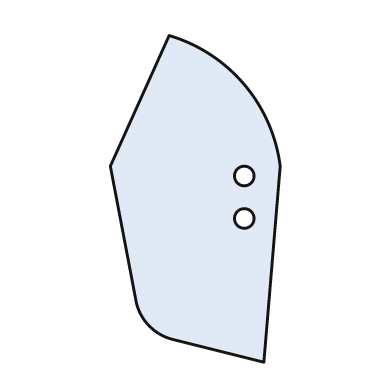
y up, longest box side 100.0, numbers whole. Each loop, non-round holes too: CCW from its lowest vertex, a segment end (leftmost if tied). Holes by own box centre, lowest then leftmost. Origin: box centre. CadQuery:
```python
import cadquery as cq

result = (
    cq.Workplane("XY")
    .moveTo(21.0, -50.0)
    .lineTo(26.0, 10.0)
    .threePointArc((15.0, 35.0), (-8.0, 50.0))
    .lineTo(-26.0, 10.0)
    .lineTo(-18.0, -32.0)
    .threePointArc((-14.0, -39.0), (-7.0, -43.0))
    .close()
    .moveTo(15.0, -6.0)
    .circle(3.0)
    .moveTo(15.0, 7.0)
    .circle(3.0)
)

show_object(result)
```